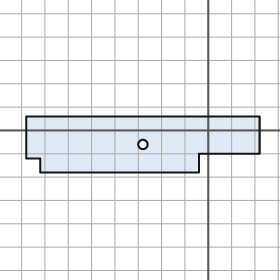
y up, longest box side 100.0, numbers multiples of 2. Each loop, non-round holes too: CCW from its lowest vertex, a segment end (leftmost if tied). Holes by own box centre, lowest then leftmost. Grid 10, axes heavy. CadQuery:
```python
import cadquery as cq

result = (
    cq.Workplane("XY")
    .moveTo(-72.0, -18.0)
    .lineTo(-4.0, -18.0)
    .lineTo(-4.0, -10.0)
    .lineTo(22.0, -10.0)
    .lineTo(22.0, 6.0)
    .lineTo(-78.0, 6.0)
    .lineTo(-78.0, -12.0)
    .lineTo(-72.0, -12.0)
    .close()
    .moveTo(-28.0, -6.0)
    .circle(2.0)
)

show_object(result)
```